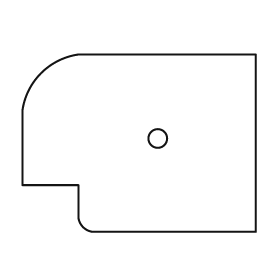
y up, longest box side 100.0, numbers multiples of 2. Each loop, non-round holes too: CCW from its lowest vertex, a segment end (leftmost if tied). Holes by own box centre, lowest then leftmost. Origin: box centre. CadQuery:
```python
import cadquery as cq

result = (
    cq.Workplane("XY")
    .moveTo(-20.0, -38.0)
    .lineTo(50.0, -38.0)
    .lineTo(50.0, 38.0)
    .lineTo(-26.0, 38.0)
    .threePointArc((-42.0, 30.0), (-50.0, 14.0))
    .lineTo(-50.0, -18.0)
    .lineTo(-26.0, -18.0)
    .lineTo(-26.0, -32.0)
    .threePointArc((-24.0, -36.0), (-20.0, -38.0))
    .close()
    .moveTo(8.0, 2.0)
    .circle(4.0)
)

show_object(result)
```